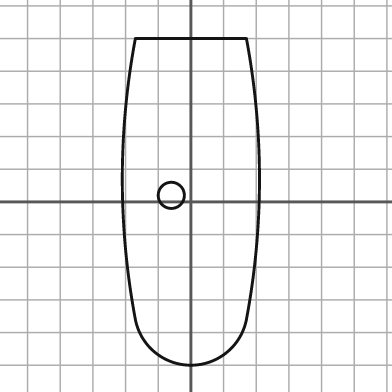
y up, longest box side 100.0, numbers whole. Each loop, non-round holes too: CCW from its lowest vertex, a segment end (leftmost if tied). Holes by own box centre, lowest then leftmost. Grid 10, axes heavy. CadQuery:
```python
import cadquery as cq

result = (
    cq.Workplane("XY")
    .moveTo(-17.0, -36.0)
    .threePointArc((0.0, -50.0), (17.0, -36.0))
    .threePointArc((21.0, 7.0), (17.0, 50.0))
    .lineTo(-17.0, 50.0)
    .threePointArc((-21.0, 7.0), (-17.0, -36.0))
    .close()
    .moveTo(-6.0, 2.0)
    .circle(4.0)
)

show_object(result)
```